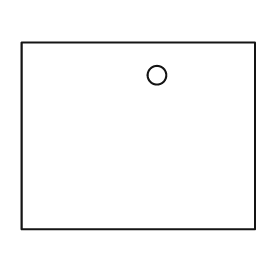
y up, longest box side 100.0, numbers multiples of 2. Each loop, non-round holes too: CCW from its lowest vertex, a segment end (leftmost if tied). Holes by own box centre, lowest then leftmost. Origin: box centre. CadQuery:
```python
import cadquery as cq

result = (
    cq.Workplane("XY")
    .moveTo(-50.0, -40.0)
    .lineTo(50.0, -40.0)
    .lineTo(50.0, 40.0)
    .lineTo(-50.0, 40.0)
    .close()
    .moveTo(8.0, 26.0)
    .circle(4.0)
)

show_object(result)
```